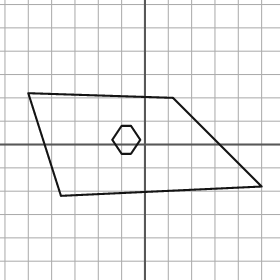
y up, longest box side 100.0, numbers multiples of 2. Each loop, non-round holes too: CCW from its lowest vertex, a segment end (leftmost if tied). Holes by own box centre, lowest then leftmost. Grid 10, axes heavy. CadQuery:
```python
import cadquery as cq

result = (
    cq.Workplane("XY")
    .moveTo(-36.0, -22.0)
    .lineTo(50.0, -18.0)
    .lineTo(12.0, 20.0)
    .lineTo(-50.0, 22.0)
    .close()
    .moveTo(-10.0, -4.0)
    .lineTo(-6.0, -4.0)
    .lineTo(-2.0, 2.0)
    .lineTo(-6.0, 8.0)
    .lineTo(-10.0, 8.0)
    .lineTo(-14.0, 2.0)
    .close()
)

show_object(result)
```